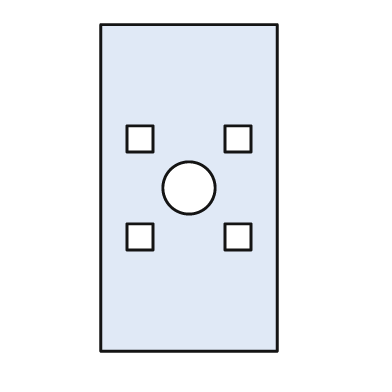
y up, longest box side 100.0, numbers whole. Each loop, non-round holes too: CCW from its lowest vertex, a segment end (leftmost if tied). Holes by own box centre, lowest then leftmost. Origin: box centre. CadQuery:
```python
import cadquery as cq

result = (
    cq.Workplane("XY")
    .moveTo(-27.0, -50.0)
    .lineTo(27.0, -50.0)
    .lineTo(27.0, 50.0)
    .lineTo(-27.0, 50.0)
    .close()
    .moveTo(-19.0, -19.0)
    .lineTo(-11.0, -19.0)
    .lineTo(-11.0, -11.0)
    .lineTo(-19.0, -11.0)
    .close()
    .moveTo(11.0, -19.0)
    .lineTo(19.0, -19.0)
    .lineTo(19.0, -11.0)
    .lineTo(11.0, -11.0)
    .close()
    .moveTo(0.0, 0.0)
    .circle(8.0)
    .moveTo(-19.0, 11.0)
    .lineTo(-11.0, 11.0)
    .lineTo(-11.0, 19.0)
    .lineTo(-19.0, 19.0)
    .close()
    .moveTo(11.0, 11.0)
    .lineTo(19.0, 11.0)
    .lineTo(19.0, 19.0)
    .lineTo(11.0, 19.0)
    .close()
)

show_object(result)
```